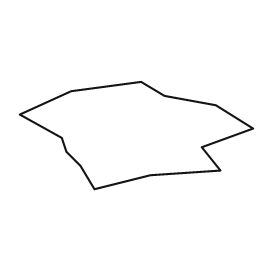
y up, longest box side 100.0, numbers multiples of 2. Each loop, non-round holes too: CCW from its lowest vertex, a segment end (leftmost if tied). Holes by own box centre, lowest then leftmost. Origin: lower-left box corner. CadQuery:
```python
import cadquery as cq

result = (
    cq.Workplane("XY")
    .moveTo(32.0, 0.0)
    .lineTo(56.0, 6.0)
    .lineTo(86.0, 8.0)
    .lineTo(78.0, 18.0)
    .lineTo(100.0, 26.0)
    .lineTo(84.0, 36.0)
    .lineTo(62.0, 40.0)
    .lineTo(52.0, 46.0)
    .lineTo(22.0, 42.0)
    .lineTo(0.0, 32.0)
    .lineTo(18.0, 22.0)
    .lineTo(20.0, 16.0)
    .lineTo(26.0, 10.0)
    .close()
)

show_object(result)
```